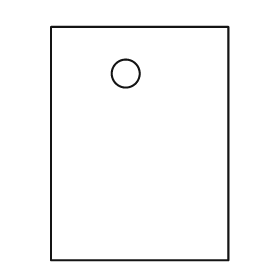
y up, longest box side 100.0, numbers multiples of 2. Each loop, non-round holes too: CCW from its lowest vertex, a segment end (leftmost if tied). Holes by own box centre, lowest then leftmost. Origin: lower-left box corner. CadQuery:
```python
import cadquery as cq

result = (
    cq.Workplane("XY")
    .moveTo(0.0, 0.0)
    .lineTo(76.0, 0.0)
    .lineTo(76.0, 100.0)
    .lineTo(0.0, 100.0)
    .close()
    .moveTo(32.0, 80.0)
    .circle(6.0)
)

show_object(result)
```